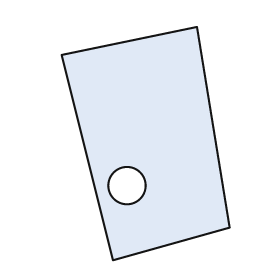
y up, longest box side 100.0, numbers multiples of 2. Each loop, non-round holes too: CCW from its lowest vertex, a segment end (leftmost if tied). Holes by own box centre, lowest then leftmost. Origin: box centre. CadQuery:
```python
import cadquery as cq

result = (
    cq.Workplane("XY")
    .moveTo(-14.0, -50.0)
    .lineTo(36.0, -36.0)
    .lineTo(22.0, 50.0)
    .lineTo(-36.0, 38.0)
    .close()
    .moveTo(-8.0, -18.0)
    .circle(8.0)
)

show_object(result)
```